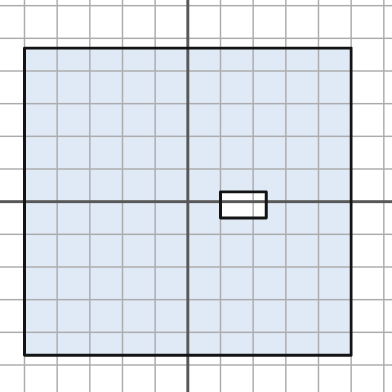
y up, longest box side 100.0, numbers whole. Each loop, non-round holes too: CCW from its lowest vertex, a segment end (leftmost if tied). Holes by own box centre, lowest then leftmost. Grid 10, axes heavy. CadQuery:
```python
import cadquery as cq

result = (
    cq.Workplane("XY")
    .moveTo(-50.0, -47.0)
    .lineTo(50.0, -47.0)
    .lineTo(50.0, 47.0)
    .lineTo(-50.0, 47.0)
    .close()
    .moveTo(10.0, -5.0)
    .lineTo(24.0, -5.0)
    .lineTo(24.0, 3.0)
    .lineTo(10.0, 3.0)
    .close()
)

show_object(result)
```